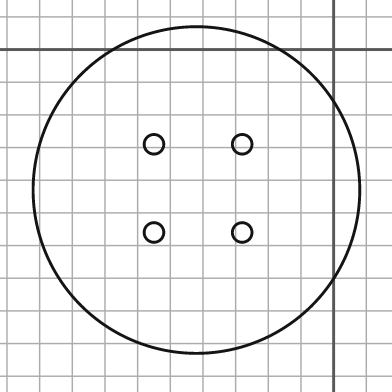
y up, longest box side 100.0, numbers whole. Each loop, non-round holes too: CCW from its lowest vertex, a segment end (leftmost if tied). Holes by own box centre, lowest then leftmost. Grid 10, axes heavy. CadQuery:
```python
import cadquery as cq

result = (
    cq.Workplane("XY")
    .moveTo(-42.0, -43.0)
    .circle(50.0)
    .moveTo(-55.0, -56.0)
    .circle(3.0)
    .moveTo(-28.0, -56.0)
    .circle(3.0)
    .moveTo(-55.0, -29.0)
    .circle(3.0)
    .moveTo(-28.0, -29.0)
    .circle(3.0)
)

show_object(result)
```